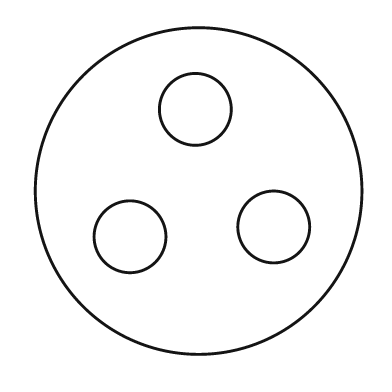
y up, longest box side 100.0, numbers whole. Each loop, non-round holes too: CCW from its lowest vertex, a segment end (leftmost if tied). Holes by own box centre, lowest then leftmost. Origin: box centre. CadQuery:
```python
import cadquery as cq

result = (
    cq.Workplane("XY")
    .moveTo(0.0, 0.0)
    .circle(50.0)
    .moveTo(-21.0, -14.0)
    .circle(11.0)
    .moveTo(23.0, -11.0)
    .circle(11.0)
    .moveTo(-1.0, 25.0)
    .circle(11.0)
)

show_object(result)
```